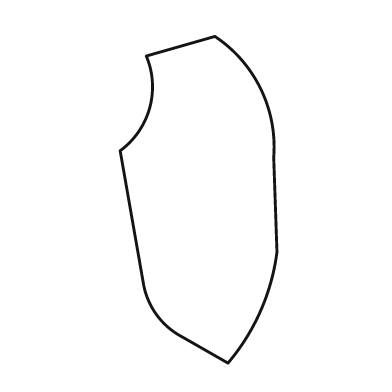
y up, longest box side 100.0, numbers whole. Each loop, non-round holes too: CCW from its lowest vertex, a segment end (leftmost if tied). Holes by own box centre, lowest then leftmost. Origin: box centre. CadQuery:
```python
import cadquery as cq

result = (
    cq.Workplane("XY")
    .moveTo(9.0, -50.0)
    .threePointArc((19.0, -34.0), (24.0, -16.0))
    .lineTo(23.0, 13.0)
    .threePointArc((19.0, 34.0), (5.0, 50.0))
    .lineTo(-16.0, 44.0)
    .threePointArc((-15.0, 28.0), (-24.0, 15.0))
    .lineTo(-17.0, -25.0)
    .threePointArc((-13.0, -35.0), (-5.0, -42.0))
    .close()
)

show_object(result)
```